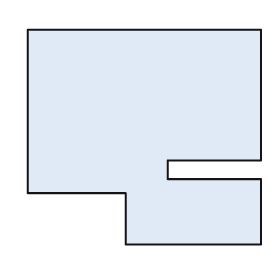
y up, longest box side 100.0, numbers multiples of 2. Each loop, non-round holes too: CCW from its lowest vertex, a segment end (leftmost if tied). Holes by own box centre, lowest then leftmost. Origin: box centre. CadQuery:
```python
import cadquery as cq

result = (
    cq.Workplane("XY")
    .moveTo(-8.0, -46.0)
    .lineTo(50.0, -46.0)
    .lineTo(50.0, -18.0)
    .lineTo(10.0, -18.0)
    .lineTo(10.0, -10.0)
    .lineTo(50.0, -10.0)
    .lineTo(50.0, 46.0)
    .lineTo(-50.0, 46.0)
    .lineTo(-50.0, -24.0)
    .lineTo(-8.0, -24.0)
    .close()
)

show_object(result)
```